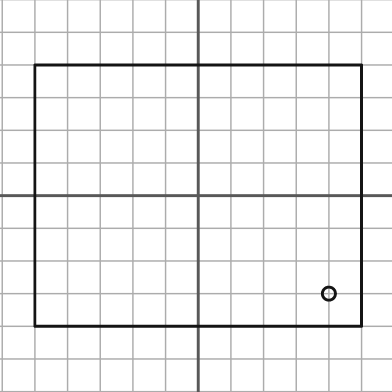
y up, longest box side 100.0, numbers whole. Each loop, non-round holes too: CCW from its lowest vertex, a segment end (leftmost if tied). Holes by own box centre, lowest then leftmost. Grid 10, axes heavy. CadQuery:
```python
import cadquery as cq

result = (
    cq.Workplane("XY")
    .moveTo(-50.0, -40.0)
    .lineTo(50.0, -40.0)
    .lineTo(50.0, 40.0)
    .lineTo(-50.0, 40.0)
    .close()
    .moveTo(40.0, -30.0)
    .circle(2.0)
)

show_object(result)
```